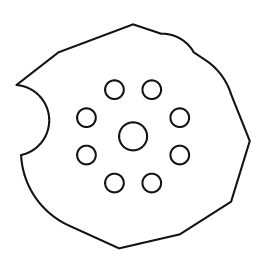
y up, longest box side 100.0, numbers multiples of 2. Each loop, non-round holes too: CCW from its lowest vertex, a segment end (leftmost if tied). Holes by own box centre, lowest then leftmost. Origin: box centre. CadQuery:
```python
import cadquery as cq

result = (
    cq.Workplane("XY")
    .moveTo(-6.0, -48.0)
    .lineTo(20.0, -42.0)
    .lineTo(42.0, -28.0)
    .lineTo(50.0, -2.0)
    .lineTo(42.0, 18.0)
    .threePointArc((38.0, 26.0), (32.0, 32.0))
    .lineTo(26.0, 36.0)
    .threePointArc((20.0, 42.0), (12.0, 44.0))
    .lineTo(0.0, 48.0)
    .lineTo(-32.0, 36.0)
    .lineTo(-50.0, 22.0)
    .threePointArc((-36.0, 8.0), (-48.0, -8.0))
    .threePointArc((-42.0, -26.0), (-28.0, -38.0))
    .close()
    .moveTo(-8.0, -20.0)
    .circle(4.0)
    .moveTo(8.0, -20.0)
    .circle(4.0)
    .moveTo(-20.0, -8.0)
    .circle(4.0)
    .moveTo(20.0, -8.0)
    .circle(4.0)
    .moveTo(0.0, 0.0)
    .circle(6.0)
    .moveTo(-20.0, 8.0)
    .circle(4.0)
    .moveTo(20.0, 8.0)
    .circle(4.0)
    .moveTo(-8.0, 20.0)
    .circle(4.0)
    .moveTo(8.0, 20.0)
    .circle(4.0)
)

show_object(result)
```